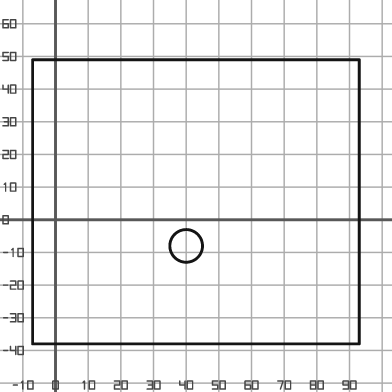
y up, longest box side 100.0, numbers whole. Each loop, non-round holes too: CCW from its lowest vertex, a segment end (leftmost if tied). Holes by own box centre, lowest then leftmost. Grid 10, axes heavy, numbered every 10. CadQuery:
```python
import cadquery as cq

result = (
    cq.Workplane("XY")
    .moveTo(-7.0, -38.0)
    .lineTo(93.0, -38.0)
    .lineTo(93.0, 49.0)
    .lineTo(-7.0, 49.0)
    .close()
    .moveTo(40.0, -8.0)
    .circle(5.0)
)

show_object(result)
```